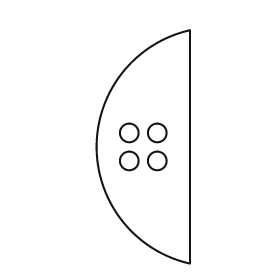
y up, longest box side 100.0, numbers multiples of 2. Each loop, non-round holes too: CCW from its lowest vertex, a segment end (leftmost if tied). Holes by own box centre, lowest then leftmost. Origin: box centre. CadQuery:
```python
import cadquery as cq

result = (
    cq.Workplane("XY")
    .moveTo(20.0, -50.0)
    .lineTo(20.0, 50.0)
    .threePointArc((-20.0, 0.0), (20.0, -50.0))
    .close()
    .moveTo(-6.0, -6.0)
    .circle(4.0)
    .moveTo(6.0, -6.0)
    .circle(4.0)
    .moveTo(-6.0, 6.0)
    .circle(4.0)
    .moveTo(6.0, 6.0)
    .circle(4.0)
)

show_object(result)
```